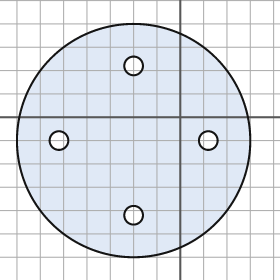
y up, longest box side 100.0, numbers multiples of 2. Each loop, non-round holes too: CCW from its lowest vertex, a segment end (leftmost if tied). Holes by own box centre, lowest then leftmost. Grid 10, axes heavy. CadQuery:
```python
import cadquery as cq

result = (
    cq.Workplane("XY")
    .moveTo(-20.0, -10.0)
    .circle(50.0)
    .moveTo(-20.0, -42.0)
    .circle(4.0)
    .moveTo(-52.0, -10.0)
    .circle(4.0)
    .moveTo(12.0, -10.0)
    .circle(4.0)
    .moveTo(-20.0, 22.0)
    .circle(4.0)
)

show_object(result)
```